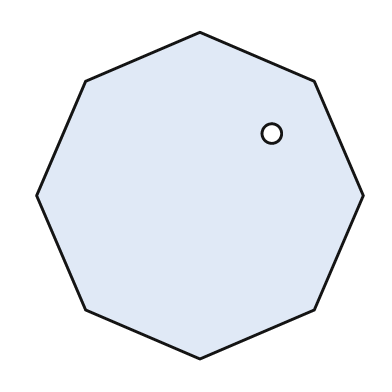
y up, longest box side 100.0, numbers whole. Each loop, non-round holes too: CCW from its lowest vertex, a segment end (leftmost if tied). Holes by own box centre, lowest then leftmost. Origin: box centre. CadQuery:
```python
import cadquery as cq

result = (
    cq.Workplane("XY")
    .moveTo(0.0, -50.0)
    .lineTo(35.0, -35.0)
    .lineTo(50.0, 0.0)
    .lineTo(35.0, 35.0)
    .lineTo(0.0, 50.0)
    .lineTo(-35.0, 35.0)
    .lineTo(-50.0, 0.0)
    .lineTo(-35.0, -35.0)
    .close()
    .moveTo(22.0, 19.0)
    .circle(3.0)
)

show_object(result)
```